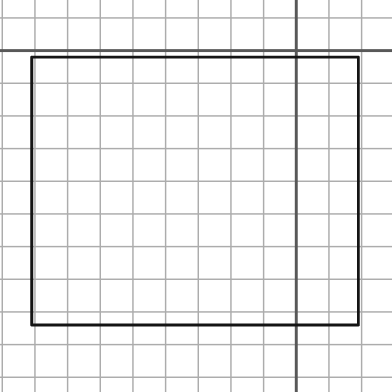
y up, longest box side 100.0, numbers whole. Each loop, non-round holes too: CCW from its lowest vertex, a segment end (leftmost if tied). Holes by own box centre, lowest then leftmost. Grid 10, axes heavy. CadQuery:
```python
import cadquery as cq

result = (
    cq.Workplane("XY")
    .moveTo(-81.0, -84.0)
    .lineTo(19.0, -84.0)
    .lineTo(19.0, -2.0)
    .lineTo(-81.0, -2.0)
    .close()
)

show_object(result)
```